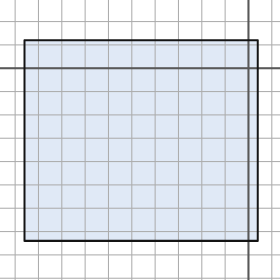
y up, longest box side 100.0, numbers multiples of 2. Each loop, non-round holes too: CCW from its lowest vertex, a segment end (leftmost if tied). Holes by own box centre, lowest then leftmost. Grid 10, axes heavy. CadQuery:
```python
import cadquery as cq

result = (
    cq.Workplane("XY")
    .moveTo(-96.0, -74.0)
    .lineTo(4.0, -74.0)
    .lineTo(4.0, 12.0)
    .lineTo(-96.0, 12.0)
    .close()
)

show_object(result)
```